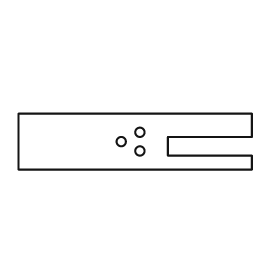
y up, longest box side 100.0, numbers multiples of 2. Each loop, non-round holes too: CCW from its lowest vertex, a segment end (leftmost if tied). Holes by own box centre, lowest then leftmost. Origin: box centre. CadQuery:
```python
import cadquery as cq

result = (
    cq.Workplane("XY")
    .moveTo(-50.0, -12.0)
    .lineTo(50.0, -12.0)
    .lineTo(50.0, -6.0)
    .lineTo(14.0, -6.0)
    .lineTo(14.0, 2.0)
    .lineTo(50.0, 2.0)
    .lineTo(50.0, 12.0)
    .lineTo(-50.0, 12.0)
    .close()
    .moveTo(2.0, -4.0)
    .circle(2.0)
    .moveTo(-6.0, 0.0)
    .circle(2.0)
    .moveTo(2.0, 4.0)
    .circle(2.0)
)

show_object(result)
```